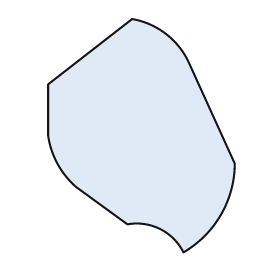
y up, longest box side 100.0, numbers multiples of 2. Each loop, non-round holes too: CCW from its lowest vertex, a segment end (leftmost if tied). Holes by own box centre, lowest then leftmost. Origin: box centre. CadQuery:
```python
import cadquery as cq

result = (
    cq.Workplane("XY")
    .moveTo(18.0, -50.0)
    .threePointArc((34.0, -34.0), (40.0, -12.0))
    .lineTo(20.0, 32.0)
    .threePointArc((10.0, 44.0), (-4.0, 50.0))
    .lineTo(-40.0, 22.0)
    .lineTo(-40.0, 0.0)
    .threePointArc((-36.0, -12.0), (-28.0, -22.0))
    .lineTo(-6.0, -38.0)
    .threePointArc((8.0, -40.0), (18.0, -50.0))
    .close()
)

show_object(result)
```